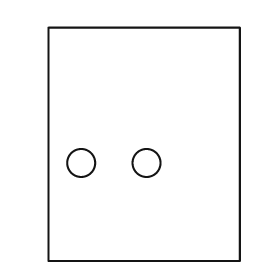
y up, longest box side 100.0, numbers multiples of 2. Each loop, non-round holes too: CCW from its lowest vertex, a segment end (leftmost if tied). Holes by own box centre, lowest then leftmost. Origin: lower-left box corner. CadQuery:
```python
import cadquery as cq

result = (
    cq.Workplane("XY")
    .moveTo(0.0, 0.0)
    .lineTo(82.0, 0.0)
    .lineTo(82.0, 100.0)
    .lineTo(0.0, 100.0)
    .close()
    .moveTo(14.0, 42.0)
    .circle(6.0)
    .moveTo(42.0, 42.0)
    .circle(6.0)
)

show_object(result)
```